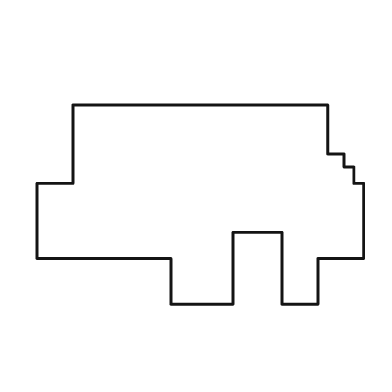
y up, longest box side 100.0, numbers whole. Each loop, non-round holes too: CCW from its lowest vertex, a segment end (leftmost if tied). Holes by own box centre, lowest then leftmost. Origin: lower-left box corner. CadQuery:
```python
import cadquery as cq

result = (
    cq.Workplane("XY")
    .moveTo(41.0, 0.0)
    .lineTo(60.0, 0.0)
    .lineTo(60.0, 22.0)
    .lineTo(75.0, 22.0)
    .lineTo(75.0, 0.0)
    .lineTo(86.0, 0.0)
    .lineTo(86.0, 14.0)
    .lineTo(100.0, 14.0)
    .lineTo(100.0, 37.0)
    .lineTo(97.0, 37.0)
    .lineTo(97.0, 42.0)
    .lineTo(94.0, 42.0)
    .lineTo(94.0, 46.0)
    .lineTo(89.0, 46.0)
    .lineTo(89.0, 61.0)
    .lineTo(11.0, 61.0)
    .lineTo(11.0, 37.0)
    .lineTo(0.0, 37.0)
    .lineTo(0.0, 14.0)
    .lineTo(41.0, 14.0)
    .close()
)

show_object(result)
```